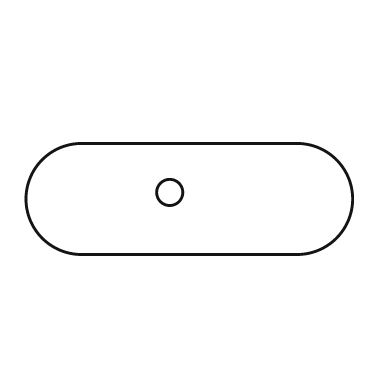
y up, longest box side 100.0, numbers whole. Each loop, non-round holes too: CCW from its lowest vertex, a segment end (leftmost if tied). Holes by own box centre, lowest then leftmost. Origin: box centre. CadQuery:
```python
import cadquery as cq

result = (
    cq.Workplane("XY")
    .moveTo(-33.0, -17.0)
    .lineTo(33.0, -17.0)
    .threePointArc((50.0, 0.0), (33.0, 17.0))
    .lineTo(-33.0, 17.0)
    .threePointArc((-50.0, 0.0), (-33.0, -17.0))
    .close()
    .moveTo(-6.0, 2.0)
    .circle(4.0)
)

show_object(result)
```